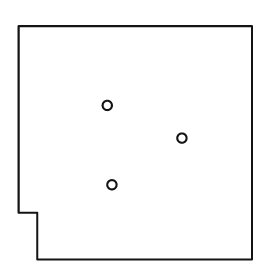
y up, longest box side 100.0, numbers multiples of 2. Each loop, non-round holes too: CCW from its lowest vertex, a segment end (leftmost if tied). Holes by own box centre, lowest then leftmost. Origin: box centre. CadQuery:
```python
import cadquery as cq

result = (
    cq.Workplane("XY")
    .moveTo(-42.0, -50.0)
    .lineTo(50.0, -50.0)
    .lineTo(50.0, 50.0)
    .lineTo(-50.0, 50.0)
    .lineTo(-50.0, -30.0)
    .lineTo(-42.0, -30.0)
    .close()
    .moveTo(-10.0, -18.0)
    .circle(2.0)
    .moveTo(20.0, 2.0)
    .circle(2.0)
    .moveTo(-12.0, 16.0)
    .circle(2.0)
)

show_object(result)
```